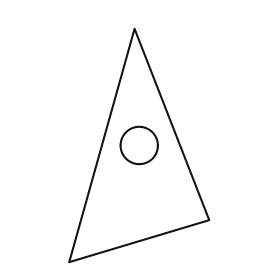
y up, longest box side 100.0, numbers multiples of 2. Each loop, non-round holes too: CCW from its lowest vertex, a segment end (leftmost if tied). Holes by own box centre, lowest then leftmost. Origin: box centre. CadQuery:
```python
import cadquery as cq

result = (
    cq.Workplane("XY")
    .moveTo(-30.0, -50.0)
    .lineTo(30.0, -32.0)
    .lineTo(-2.0, 50.0)
    .close()
    .moveTo(0.0, 0.0)
    .circle(8.0)
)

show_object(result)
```